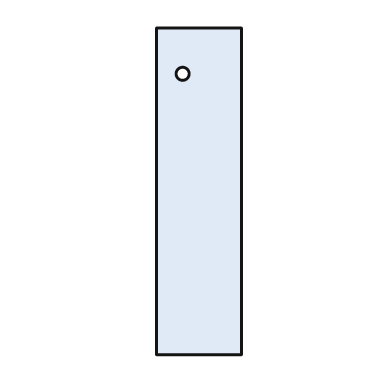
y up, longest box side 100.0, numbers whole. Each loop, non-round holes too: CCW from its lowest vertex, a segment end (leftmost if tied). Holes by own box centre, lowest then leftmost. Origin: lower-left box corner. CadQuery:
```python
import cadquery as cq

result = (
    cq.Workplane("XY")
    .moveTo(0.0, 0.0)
    .lineTo(26.0, 0.0)
    .lineTo(26.0, 100.0)
    .lineTo(0.0, 100.0)
    .close()
    .moveTo(8.0, 86.0)
    .circle(2.0)
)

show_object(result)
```